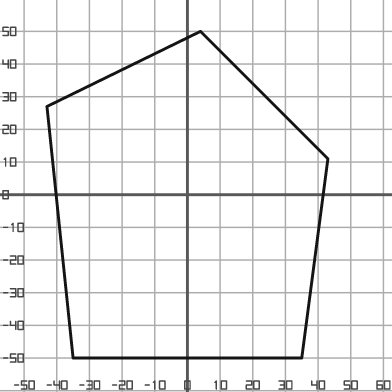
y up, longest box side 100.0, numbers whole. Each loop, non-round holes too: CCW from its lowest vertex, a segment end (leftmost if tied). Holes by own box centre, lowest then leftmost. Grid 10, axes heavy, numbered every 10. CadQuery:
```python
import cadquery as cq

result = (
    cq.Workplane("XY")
    .moveTo(-35.0, -50.0)
    .lineTo(35.0, -50.0)
    .lineTo(43.0, 11.0)
    .lineTo(4.0, 50.0)
    .lineTo(-43.0, 27.0)
    .close()
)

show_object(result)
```